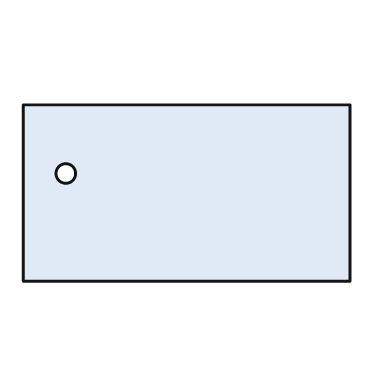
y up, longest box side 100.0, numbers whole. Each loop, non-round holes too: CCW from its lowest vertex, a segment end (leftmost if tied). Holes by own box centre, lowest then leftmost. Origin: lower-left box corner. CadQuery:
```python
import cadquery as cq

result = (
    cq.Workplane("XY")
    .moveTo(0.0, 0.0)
    .lineTo(100.0, 0.0)
    .lineTo(100.0, 54.0)
    .lineTo(0.0, 54.0)
    .close()
    .moveTo(13.0, 33.0)
    .circle(3.0)
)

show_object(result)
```